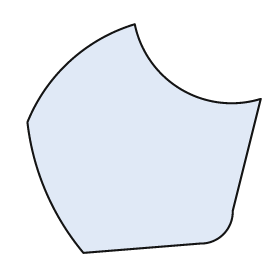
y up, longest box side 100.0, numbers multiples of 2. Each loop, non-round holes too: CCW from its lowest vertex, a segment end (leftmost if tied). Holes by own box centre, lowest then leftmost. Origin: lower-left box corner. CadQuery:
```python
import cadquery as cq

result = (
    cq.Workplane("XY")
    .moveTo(24.0, 0.0)
    .lineTo(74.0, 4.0)
    .threePointArc((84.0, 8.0), (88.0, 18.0))
    .lineTo(100.0, 66.0)
    .threePointArc((66.0, 70.0), (46.0, 98.0))
    .threePointArc((18.0, 82.0), (0.0, 56.0))
    .threePointArc((8.0, 26.0), (24.0, 0.0))
    .close()
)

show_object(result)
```